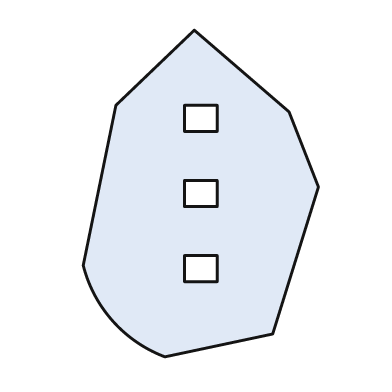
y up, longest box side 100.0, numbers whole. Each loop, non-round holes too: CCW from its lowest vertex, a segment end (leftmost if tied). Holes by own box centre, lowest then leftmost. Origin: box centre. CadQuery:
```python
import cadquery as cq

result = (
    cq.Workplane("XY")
    .moveTo(-11.0, -50.0)
    .lineTo(22.0, -43.0)
    .lineTo(36.0, 2.0)
    .lineTo(27.0, 25.0)
    .lineTo(-2.0, 50.0)
    .lineTo(-26.0, 27.0)
    .lineTo(-36.0, -22.0)
    .threePointArc((-27.0, -39.0), (-11.0, -50.0))
    .close()
    .moveTo(-5.0, -27.0)
    .lineTo(5.0, -27.0)
    .lineTo(5.0, -19.0)
    .lineTo(-5.0, -19.0)
    .close()
    .moveTo(-5.0, -4.0)
    .lineTo(5.0, -4.0)
    .lineTo(5.0, 4.0)
    .lineTo(-5.0, 4.0)
    .close()
    .moveTo(-5.0, 19.0)
    .lineTo(5.0, 19.0)
    .lineTo(5.0, 27.0)
    .lineTo(-5.0, 27.0)
    .close()
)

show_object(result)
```